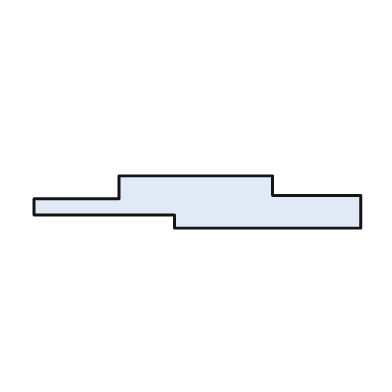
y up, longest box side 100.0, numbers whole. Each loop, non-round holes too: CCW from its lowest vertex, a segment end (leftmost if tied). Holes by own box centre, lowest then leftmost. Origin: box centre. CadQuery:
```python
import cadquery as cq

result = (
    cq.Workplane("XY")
    .moveTo(-7.0, -8.0)
    .lineTo(50.0, -8.0)
    .lineTo(50.0, 2.0)
    .lineTo(23.0, 2.0)
    .lineTo(23.0, 8.0)
    .lineTo(-24.0, 8.0)
    .lineTo(-24.0, 1.0)
    .lineTo(-50.0, 1.0)
    .lineTo(-50.0, -4.0)
    .lineTo(-7.0, -4.0)
    .close()
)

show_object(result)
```